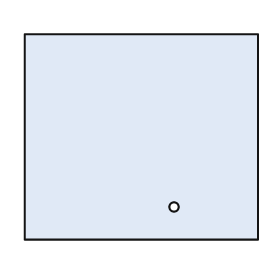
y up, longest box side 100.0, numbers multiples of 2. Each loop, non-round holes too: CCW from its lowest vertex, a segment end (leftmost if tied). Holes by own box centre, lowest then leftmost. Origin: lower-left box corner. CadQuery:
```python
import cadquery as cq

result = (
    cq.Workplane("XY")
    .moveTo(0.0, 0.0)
    .lineTo(100.0, 0.0)
    .lineTo(100.0, 88.0)
    .lineTo(0.0, 88.0)
    .close()
    .moveTo(64.0, 14.0)
    .circle(2.0)
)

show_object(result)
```